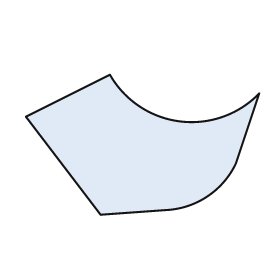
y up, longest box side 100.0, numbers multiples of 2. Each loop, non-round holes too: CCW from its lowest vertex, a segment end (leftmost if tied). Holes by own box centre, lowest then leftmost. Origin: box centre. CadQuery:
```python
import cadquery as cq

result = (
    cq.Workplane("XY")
    .moveTo(-18.0, -30.0)
    .lineTo(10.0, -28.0)
    .threePointArc((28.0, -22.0), (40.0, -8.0))
    .lineTo(50.0, 22.0)
    .threePointArc((16.0, 10.0), (-14.0, 30.0))
    .lineTo(-50.0, 12.0)
    .close()
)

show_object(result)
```